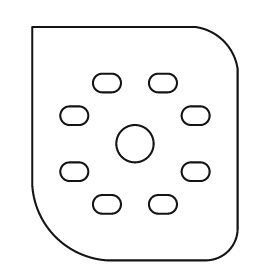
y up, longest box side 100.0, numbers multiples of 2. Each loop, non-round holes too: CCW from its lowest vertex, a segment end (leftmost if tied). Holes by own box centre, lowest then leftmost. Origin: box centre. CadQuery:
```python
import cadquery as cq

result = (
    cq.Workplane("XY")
    .moveTo(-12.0, -50.0)
    .lineTo(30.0, -50.0)
    .threePointArc((40.0, -46.0), (44.0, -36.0))
    .lineTo(44.0, 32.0)
    .threePointArc((38.0, 44.0), (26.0, 50.0))
    .lineTo(-44.0, 50.0)
    .lineTo(-44.0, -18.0)
    .threePointArc((-34.0, -40.0), (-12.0, -50.0))
    .close()
    .moveTo(-14.0, -30.0)
    .lineTo(-10.0, -30.0)
    .threePointArc((-6.0, -26.0), (-10.0, -22.0))
    .lineTo(-14.0, -22.0)
    .threePointArc((-18.0, -26.0), (-14.0, -30.0))
    .close()
    .moveTo(10.0, -30.0)
    .lineTo(14.0, -30.0)
    .threePointArc((18.0, -26.0), (14.0, -22.0))
    .lineTo(10.0, -22.0)
    .threePointArc((6.0, -26.0), (10.0, -30.0))
    .close()
    .moveTo(-28.0, -16.0)
    .lineTo(-24.0, -16.0)
    .threePointArc((-20.0, -12.0), (-24.0, -8.0))
    .lineTo(-28.0, -8.0)
    .threePointArc((-32.0, -12.0), (-28.0, -16.0))
    .close()
    .moveTo(24.0, -16.0)
    .lineTo(28.0, -16.0)
    .threePointArc((32.0, -12.0), (28.0, -8.0))
    .lineTo(24.0, -8.0)
    .threePointArc((20.0, -12.0), (24.0, -16.0))
    .close()
    .moveTo(0.0, 0.0)
    .circle(8.0)
    .moveTo(-28.0, 8.0)
    .lineTo(-24.0, 8.0)
    .threePointArc((-20.0, 12.0), (-24.0, 16.0))
    .lineTo(-28.0, 16.0)
    .threePointArc((-32.0, 12.0), (-28.0, 8.0))
    .close()
    .moveTo(24.0, 8.0)
    .lineTo(28.0, 8.0)
    .threePointArc((32.0, 12.0), (28.0, 16.0))
    .lineTo(24.0, 16.0)
    .threePointArc((20.0, 12.0), (24.0, 8.0))
    .close()
    .moveTo(-14.0, 22.0)
    .lineTo(-10.0, 22.0)
    .threePointArc((-6.0, 26.0), (-10.0, 30.0))
    .lineTo(-14.0, 30.0)
    .threePointArc((-18.0, 26.0), (-14.0, 22.0))
    .close()
    .moveTo(10.0, 22.0)
    .lineTo(14.0, 22.0)
    .threePointArc((18.0, 26.0), (14.0, 30.0))
    .lineTo(10.0, 30.0)
    .threePointArc((6.0, 26.0), (10.0, 22.0))
    .close()
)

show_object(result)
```